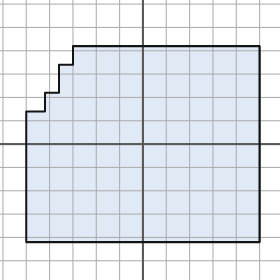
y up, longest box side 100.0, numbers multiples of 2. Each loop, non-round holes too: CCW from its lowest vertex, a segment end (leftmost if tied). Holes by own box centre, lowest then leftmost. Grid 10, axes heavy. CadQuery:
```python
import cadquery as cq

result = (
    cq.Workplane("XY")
    .moveTo(-50.0, -42.0)
    .lineTo(50.0, -42.0)
    .lineTo(50.0, 42.0)
    .lineTo(-30.0, 42.0)
    .lineTo(-30.0, 34.0)
    .lineTo(-36.0, 34.0)
    .lineTo(-36.0, 22.0)
    .lineTo(-42.0, 22.0)
    .lineTo(-42.0, 14.0)
    .lineTo(-50.0, 14.0)
    .close()
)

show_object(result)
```